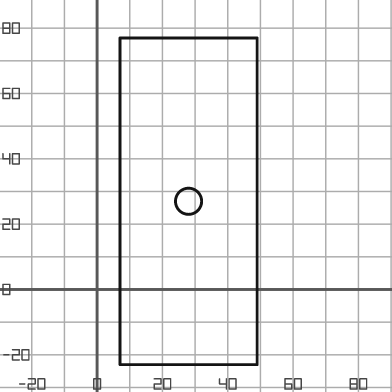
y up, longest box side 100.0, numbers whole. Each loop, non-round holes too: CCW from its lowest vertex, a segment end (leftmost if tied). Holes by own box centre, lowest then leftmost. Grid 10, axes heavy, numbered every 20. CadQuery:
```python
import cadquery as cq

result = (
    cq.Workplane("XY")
    .moveTo(7.0, -23.0)
    .lineTo(49.0, -23.0)
    .lineTo(49.0, 77.0)
    .lineTo(7.0, 77.0)
    .close()
    .moveTo(28.0, 27.0)
    .circle(4.0)
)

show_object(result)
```